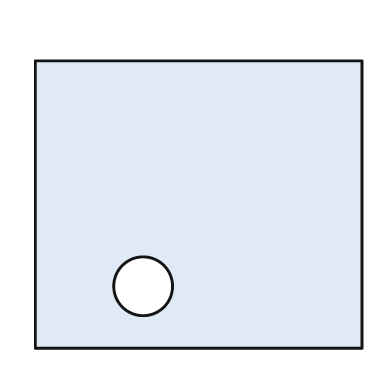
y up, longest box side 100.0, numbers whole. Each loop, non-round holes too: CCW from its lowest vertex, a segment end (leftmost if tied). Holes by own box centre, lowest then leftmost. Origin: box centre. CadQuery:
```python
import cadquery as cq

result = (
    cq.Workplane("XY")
    .moveTo(-50.0, -44.0)
    .lineTo(50.0, -44.0)
    .lineTo(50.0, 44.0)
    .lineTo(-50.0, 44.0)
    .close()
    .moveTo(-17.0, -25.0)
    .circle(9.0)
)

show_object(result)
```